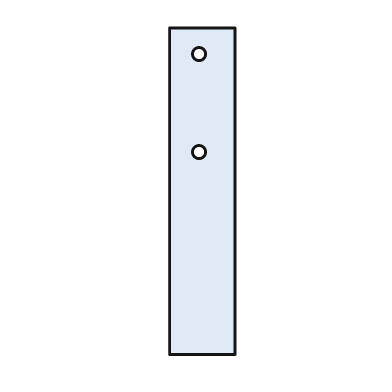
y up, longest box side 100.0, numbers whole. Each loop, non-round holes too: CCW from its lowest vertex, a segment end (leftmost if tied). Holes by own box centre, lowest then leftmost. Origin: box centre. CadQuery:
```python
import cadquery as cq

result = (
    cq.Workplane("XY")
    .moveTo(-10.0, -50.0)
    .lineTo(10.0, -50.0)
    .lineTo(10.0, 50.0)
    .lineTo(-10.0, 50.0)
    .close()
    .moveTo(-1.0, 12.0)
    .circle(2.0)
    .moveTo(-1.0, 42.0)
    .circle(2.0)
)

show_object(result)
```